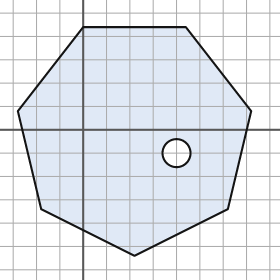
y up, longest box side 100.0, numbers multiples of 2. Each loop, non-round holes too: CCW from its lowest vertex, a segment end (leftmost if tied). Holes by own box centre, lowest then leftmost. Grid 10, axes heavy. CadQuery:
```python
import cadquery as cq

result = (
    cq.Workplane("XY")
    .moveTo(22.0, -54.0)
    .lineTo(62.0, -34.0)
    .lineTo(72.0, 8.0)
    .lineTo(44.0, 44.0)
    .lineTo(0.0, 44.0)
    .lineTo(-28.0, 8.0)
    .lineTo(-18.0, -34.0)
    .close()
    .moveTo(40.0, -10.0)
    .circle(6.0)
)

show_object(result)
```